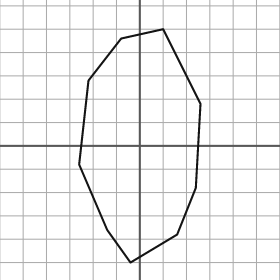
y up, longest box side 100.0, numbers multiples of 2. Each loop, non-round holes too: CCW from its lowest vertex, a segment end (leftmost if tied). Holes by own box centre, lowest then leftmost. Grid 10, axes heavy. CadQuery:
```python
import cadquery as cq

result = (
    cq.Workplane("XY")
    .moveTo(-4.0, -50.0)
    .lineTo(16.0, -38.0)
    .lineTo(24.0, -18.0)
    .lineTo(26.0, 18.0)
    .lineTo(10.0, 50.0)
    .lineTo(-8.0, 46.0)
    .lineTo(-22.0, 28.0)
    .lineTo(-26.0, -8.0)
    .lineTo(-14.0, -36.0)
    .close()
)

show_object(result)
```